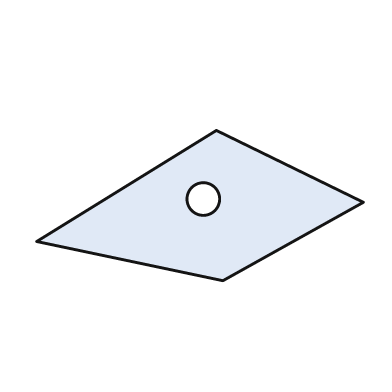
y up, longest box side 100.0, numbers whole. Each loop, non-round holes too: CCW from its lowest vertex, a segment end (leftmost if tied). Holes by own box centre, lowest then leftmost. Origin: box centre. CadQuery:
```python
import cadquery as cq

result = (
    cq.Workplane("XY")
    .moveTo(7.0, -23.0)
    .lineTo(50.0, 1.0)
    .lineTo(5.0, 23.0)
    .lineTo(-50.0, -11.0)
    .close()
    .moveTo(1.0, 2.0)
    .circle(5.0)
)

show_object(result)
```